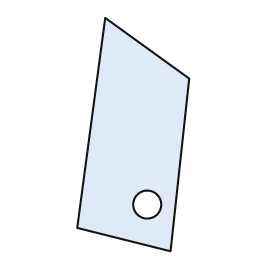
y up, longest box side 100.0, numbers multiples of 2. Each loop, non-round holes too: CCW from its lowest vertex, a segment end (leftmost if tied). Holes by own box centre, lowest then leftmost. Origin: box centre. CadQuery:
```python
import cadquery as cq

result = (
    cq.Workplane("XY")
    .moveTo(16.0, -50.0)
    .lineTo(24.0, 24.0)
    .lineTo(-12.0, 50.0)
    .lineTo(-24.0, -40.0)
    .close()
    .moveTo(6.0, -30.0)
    .circle(6.0)
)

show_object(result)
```